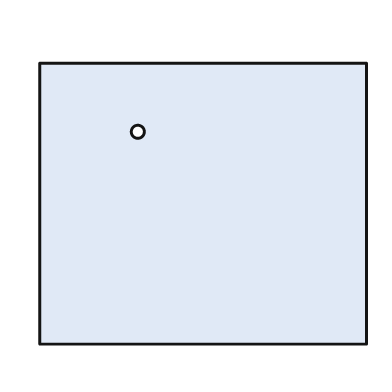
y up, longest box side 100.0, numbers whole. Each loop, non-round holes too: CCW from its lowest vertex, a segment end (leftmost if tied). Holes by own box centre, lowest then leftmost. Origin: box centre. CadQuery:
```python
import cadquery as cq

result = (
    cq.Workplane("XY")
    .moveTo(-50.0, -43.0)
    .lineTo(50.0, -43.0)
    .lineTo(50.0, 43.0)
    .lineTo(-50.0, 43.0)
    .close()
    .moveTo(-20.0, 22.0)
    .circle(2.0)
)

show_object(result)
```